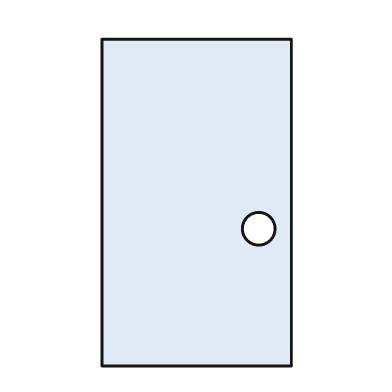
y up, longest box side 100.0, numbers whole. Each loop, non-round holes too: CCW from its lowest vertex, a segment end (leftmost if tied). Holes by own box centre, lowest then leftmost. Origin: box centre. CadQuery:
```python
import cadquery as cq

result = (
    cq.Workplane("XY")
    .moveTo(-29.0, -50.0)
    .lineTo(29.0, -50.0)
    .lineTo(29.0, 50.0)
    .lineTo(-29.0, 50.0)
    .close()
    .moveTo(19.0, -8.0)
    .circle(5.0)
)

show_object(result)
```